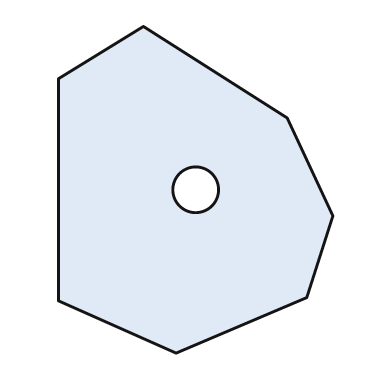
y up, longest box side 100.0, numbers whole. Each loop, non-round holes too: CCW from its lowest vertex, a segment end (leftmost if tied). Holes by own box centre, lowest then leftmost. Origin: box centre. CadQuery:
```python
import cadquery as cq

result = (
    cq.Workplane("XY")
    .moveTo(-6.0, -50.0)
    .lineTo(34.0, -33.0)
    .lineTo(42.0, -8.0)
    .lineTo(28.0, 22.0)
    .lineTo(-16.0, 50.0)
    .lineTo(-42.0, 34.0)
    .lineTo(-42.0, -34.0)
    .close()
    .moveTo(0.0, 0.0)
    .circle(7.0)
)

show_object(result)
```